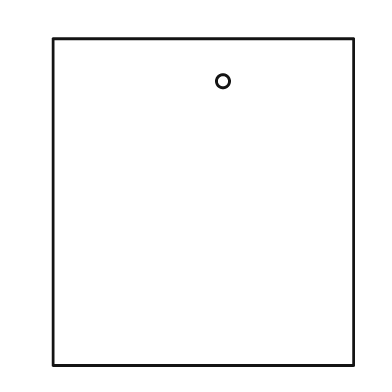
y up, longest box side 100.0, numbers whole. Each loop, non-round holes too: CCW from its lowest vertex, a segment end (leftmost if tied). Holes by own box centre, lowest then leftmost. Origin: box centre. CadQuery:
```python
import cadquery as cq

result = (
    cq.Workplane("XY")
    .moveTo(-46.0, -50.0)
    .lineTo(46.0, -50.0)
    .lineTo(46.0, 50.0)
    .lineTo(-46.0, 50.0)
    .close()
    .moveTo(6.0, 37.0)
    .circle(2.0)
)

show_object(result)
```